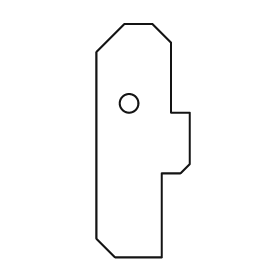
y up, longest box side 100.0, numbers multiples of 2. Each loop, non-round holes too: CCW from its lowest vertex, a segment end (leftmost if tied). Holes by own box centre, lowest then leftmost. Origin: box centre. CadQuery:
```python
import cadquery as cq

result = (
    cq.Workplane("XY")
    .moveTo(-12.0, -50.0)
    .lineTo(8.0, -50.0)
    .lineTo(8.0, -14.0)
    .lineTo(16.0, -14.0)
    .lineTo(20.0, -10.0)
    .lineTo(20.0, 12.0)
    .lineTo(12.0, 12.0)
    .lineTo(12.0, 42.0)
    .lineTo(4.0, 50.0)
    .lineTo(-8.0, 50.0)
    .lineTo(-20.0, 38.0)
    .lineTo(-20.0, -42.0)
    .close()
    .moveTo(-6.0, 16.0)
    .circle(4.0)
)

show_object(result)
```